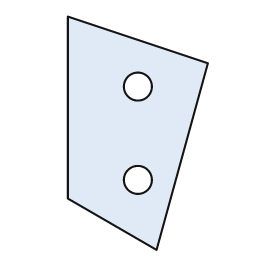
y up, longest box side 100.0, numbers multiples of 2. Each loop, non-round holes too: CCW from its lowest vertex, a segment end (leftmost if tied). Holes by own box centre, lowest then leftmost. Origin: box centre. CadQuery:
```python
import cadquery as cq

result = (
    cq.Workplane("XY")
    .moveTo(8.0, -50.0)
    .lineTo(30.0, 30.0)
    .lineTo(-30.0, 50.0)
    .lineTo(-30.0, -28.0)
    .close()
    .moveTo(0.0, -20.0)
    .circle(6.0)
    .moveTo(0.0, 20.0)
    .circle(6.0)
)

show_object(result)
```